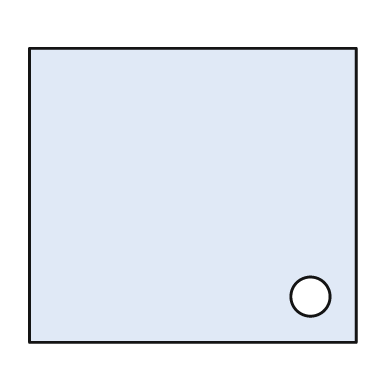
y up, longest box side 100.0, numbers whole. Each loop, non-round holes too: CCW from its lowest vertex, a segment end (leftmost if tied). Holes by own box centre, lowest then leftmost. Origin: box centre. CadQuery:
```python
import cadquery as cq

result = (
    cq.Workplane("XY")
    .moveTo(-50.0, -45.0)
    .lineTo(50.0, -45.0)
    .lineTo(50.0, 45.0)
    .lineTo(-50.0, 45.0)
    .close()
    .moveTo(36.0, -31.0)
    .circle(6.0)
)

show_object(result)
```